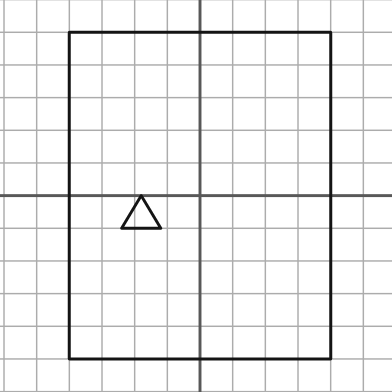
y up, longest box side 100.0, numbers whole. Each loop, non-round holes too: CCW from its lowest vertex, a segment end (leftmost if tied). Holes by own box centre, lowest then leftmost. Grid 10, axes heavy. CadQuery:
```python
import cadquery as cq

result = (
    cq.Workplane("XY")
    .moveTo(-40.0, -50.0)
    .lineTo(40.0, -50.0)
    .lineTo(40.0, 50.0)
    .lineTo(-40.0, 50.0)
    .close()
    .moveTo(-24.0, -10.0)
    .lineTo(-12.0, -10.0)
    .lineTo(-18.0, 0.0)
    .close()
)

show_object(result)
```